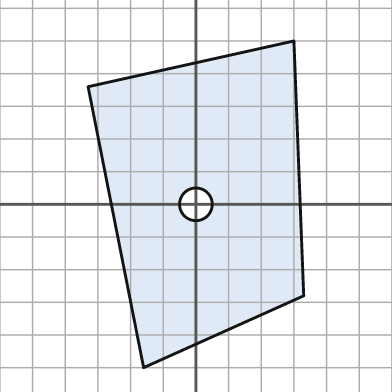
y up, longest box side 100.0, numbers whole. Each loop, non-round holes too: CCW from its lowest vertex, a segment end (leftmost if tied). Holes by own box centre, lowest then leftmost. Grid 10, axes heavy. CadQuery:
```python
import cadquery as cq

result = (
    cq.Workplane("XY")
    .moveTo(-16.0, -50.0)
    .lineTo(33.0, -28.0)
    .lineTo(30.0, 50.0)
    .lineTo(-33.0, 36.0)
    .close()
    .moveTo(0.0, 0.0)
    .circle(5.0)
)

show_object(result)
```